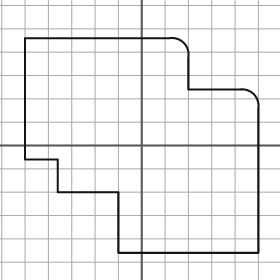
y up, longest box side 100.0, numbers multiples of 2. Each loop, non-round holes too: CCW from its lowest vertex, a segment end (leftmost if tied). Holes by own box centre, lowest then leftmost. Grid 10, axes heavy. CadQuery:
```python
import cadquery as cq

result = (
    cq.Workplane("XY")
    .moveTo(-10.0, -46.0)
    .lineTo(50.0, -46.0)
    .lineTo(50.0, 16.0)
    .threePointArc((48.0, 22.0), (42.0, 24.0))
    .lineTo(20.0, 24.0)
    .lineTo(20.0, 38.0)
    .threePointArc((18.0, 44.0), (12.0, 46.0))
    .lineTo(-50.0, 46.0)
    .lineTo(-50.0, -6.0)
    .lineTo(-36.0, -6.0)
    .lineTo(-36.0, -20.0)
    .lineTo(-10.0, -20.0)
    .close()
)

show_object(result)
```